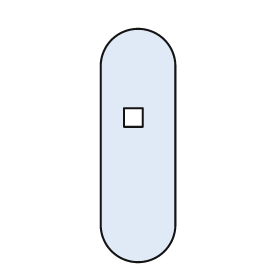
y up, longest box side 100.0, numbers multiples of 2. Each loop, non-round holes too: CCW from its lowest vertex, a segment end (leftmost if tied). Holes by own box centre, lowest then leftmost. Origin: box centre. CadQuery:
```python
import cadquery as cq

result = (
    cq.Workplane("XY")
    .moveTo(-16.0, -34.0)
    .threePointArc((0.0, -50.0), (16.0, -34.0))
    .lineTo(16.0, 34.0)
    .threePointArc((0.0, 50.0), (-16.0, 34.0))
    .close()
    .moveTo(-6.0, 8.0)
    .lineTo(2.0, 8.0)
    .lineTo(2.0, 16.0)
    .lineTo(-6.0, 16.0)
    .close()
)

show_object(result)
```